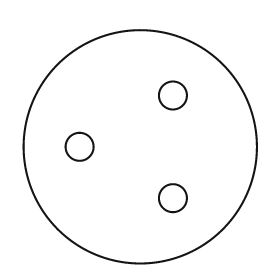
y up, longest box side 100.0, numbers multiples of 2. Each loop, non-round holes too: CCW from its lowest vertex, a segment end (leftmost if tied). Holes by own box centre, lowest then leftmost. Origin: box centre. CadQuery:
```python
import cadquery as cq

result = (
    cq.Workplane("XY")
    .moveTo(0.0, 0.0)
    .circle(50.0)
    .moveTo(14.0, -22.0)
    .circle(6.0)
    .moveTo(-26.0, 0.0)
    .circle(6.0)
    .moveTo(14.0, 22.0)
    .circle(6.0)
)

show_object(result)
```